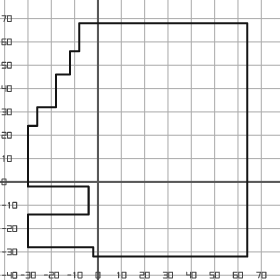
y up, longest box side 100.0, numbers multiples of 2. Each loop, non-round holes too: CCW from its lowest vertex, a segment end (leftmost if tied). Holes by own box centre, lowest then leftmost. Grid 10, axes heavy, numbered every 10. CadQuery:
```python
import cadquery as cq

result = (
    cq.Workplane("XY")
    .moveTo(-2.0, -32.0)
    .lineTo(64.0, -32.0)
    .lineTo(64.0, 68.0)
    .lineTo(-8.0, 68.0)
    .lineTo(-8.0, 56.0)
    .lineTo(-12.0, 56.0)
    .lineTo(-12.0, 46.0)
    .lineTo(-18.0, 46.0)
    .lineTo(-18.0, 32.0)
    .lineTo(-26.0, 32.0)
    .lineTo(-26.0, 24.0)
    .lineTo(-30.0, 24.0)
    .lineTo(-30.0, -2.0)
    .lineTo(-4.0, -2.0)
    .lineTo(-4.0, -14.0)
    .lineTo(-30.0, -14.0)
    .lineTo(-30.0, -28.0)
    .lineTo(-2.0, -28.0)
    .close()
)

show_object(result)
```